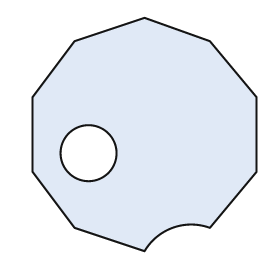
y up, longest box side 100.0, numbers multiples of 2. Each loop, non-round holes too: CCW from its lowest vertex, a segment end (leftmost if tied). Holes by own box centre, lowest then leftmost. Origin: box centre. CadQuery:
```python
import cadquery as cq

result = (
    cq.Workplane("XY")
    .moveTo(0.0, -50.0)
    .threePointArc((12.0, -40.0), (28.0, -40.0))
    .lineTo(48.0, -16.0)
    .lineTo(48.0, 16.0)
    .lineTo(28.0, 40.0)
    .lineTo(0.0, 50.0)
    .lineTo(-30.0, 40.0)
    .lineTo(-48.0, 16.0)
    .lineTo(-48.0, -16.0)
    .lineTo(-30.0, -40.0)
    .close()
    .moveTo(-24.0, -8.0)
    .circle(12.0)
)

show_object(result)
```